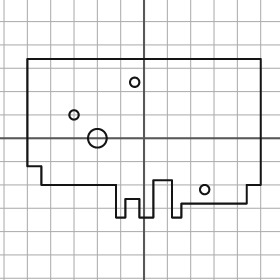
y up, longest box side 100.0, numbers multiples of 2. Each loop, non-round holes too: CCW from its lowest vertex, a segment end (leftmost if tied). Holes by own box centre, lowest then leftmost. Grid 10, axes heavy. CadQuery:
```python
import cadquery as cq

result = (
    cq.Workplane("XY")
    .moveTo(-12.0, -34.0)
    .lineTo(-8.0, -34.0)
    .lineTo(-8.0, -26.0)
    .lineTo(-2.0, -26.0)
    .lineTo(-2.0, -34.0)
    .lineTo(4.0, -34.0)
    .lineTo(4.0, -18.0)
    .lineTo(12.0, -18.0)
    .lineTo(12.0, -34.0)
    .lineTo(16.0, -34.0)
    .lineTo(16.0, -28.0)
    .lineTo(44.0, -28.0)
    .lineTo(44.0, -20.0)
    .lineTo(50.0, -20.0)
    .lineTo(50.0, 34.0)
    .lineTo(-50.0, 34.0)
    .lineTo(-50.0, -12.0)
    .lineTo(-44.0, -12.0)
    .lineTo(-44.0, -20.0)
    .lineTo(-12.0, -20.0)
    .close()
    .moveTo(26.0, -22.0)
    .circle(2.0)
    .moveTo(-20.0, 0.0)
    .circle(4.0)
    .moveTo(-30.0, 10.0)
    .circle(2.0)
    .moveTo(-4.0, 24.0)
    .circle(2.0)
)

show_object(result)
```